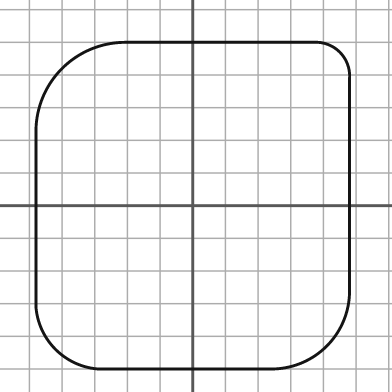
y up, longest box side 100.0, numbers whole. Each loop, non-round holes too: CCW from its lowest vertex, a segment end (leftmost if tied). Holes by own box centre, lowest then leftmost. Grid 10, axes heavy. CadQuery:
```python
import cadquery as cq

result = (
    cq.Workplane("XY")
    .moveTo(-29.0, -50.0)
    .lineTo(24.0, -50.0)
    .threePointArc((41.0, -43.0), (48.0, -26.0))
    .lineTo(48.0, 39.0)
    .threePointArc((45.0, 47.0), (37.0, 50.0))
    .lineTo(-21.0, 50.0)
    .threePointArc((-40.0, 42.0), (-48.0, 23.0))
    .lineTo(-48.0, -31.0)
    .threePointArc((-42.0, -44.0), (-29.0, -50.0))
    .close()
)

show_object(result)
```